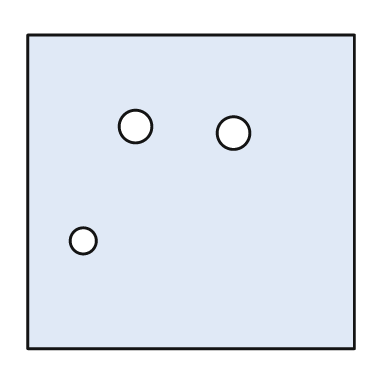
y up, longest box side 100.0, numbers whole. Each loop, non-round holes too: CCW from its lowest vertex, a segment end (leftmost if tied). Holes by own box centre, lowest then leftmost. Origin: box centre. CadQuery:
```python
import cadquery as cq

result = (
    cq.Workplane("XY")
    .moveTo(-50.0, -48.0)
    .lineTo(50.0, -48.0)
    .lineTo(50.0, 48.0)
    .lineTo(-50.0, 48.0)
    .close()
    .moveTo(-33.0, -15.0)
    .circle(4.0)
    .moveTo(13.0, 18.0)
    .circle(5.0)
    .moveTo(-17.0, 20.0)
    .circle(5.0)
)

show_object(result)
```